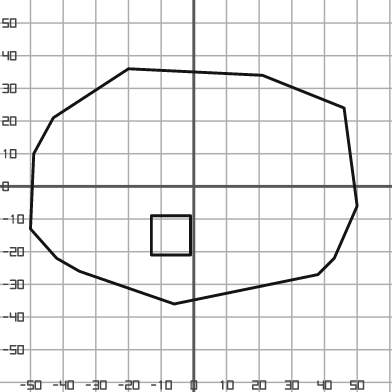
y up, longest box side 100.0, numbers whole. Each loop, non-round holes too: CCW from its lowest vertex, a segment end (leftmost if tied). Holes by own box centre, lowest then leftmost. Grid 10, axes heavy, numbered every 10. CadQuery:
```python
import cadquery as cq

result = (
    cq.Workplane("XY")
    .moveTo(-6.0, -36.0)
    .lineTo(38.0, -27.0)
    .lineTo(43.0, -22.0)
    .lineTo(50.0, -6.0)
    .lineTo(46.0, 24.0)
    .lineTo(21.0, 34.0)
    .lineTo(-20.0, 36.0)
    .lineTo(-43.0, 21.0)
    .lineTo(-49.0, 10.0)
    .lineTo(-50.0, -13.0)
    .lineTo(-42.0, -22.0)
    .lineTo(-35.0, -26.0)
    .close()
    .moveTo(-13.0, -21.0)
    .lineTo(-1.0, -21.0)
    .lineTo(-1.0, -9.0)
    .lineTo(-13.0, -9.0)
    .close()
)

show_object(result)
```